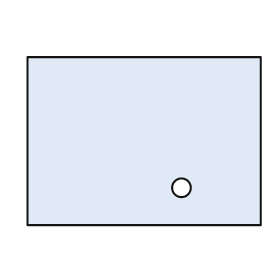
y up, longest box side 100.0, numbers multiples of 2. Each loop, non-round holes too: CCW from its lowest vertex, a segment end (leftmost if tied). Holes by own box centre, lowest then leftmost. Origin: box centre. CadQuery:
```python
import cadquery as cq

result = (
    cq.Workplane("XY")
    .moveTo(-50.0, -36.0)
    .lineTo(50.0, -36.0)
    .lineTo(50.0, 36.0)
    .lineTo(-50.0, 36.0)
    .close()
    .moveTo(16.0, -20.0)
    .circle(4.0)
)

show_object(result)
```